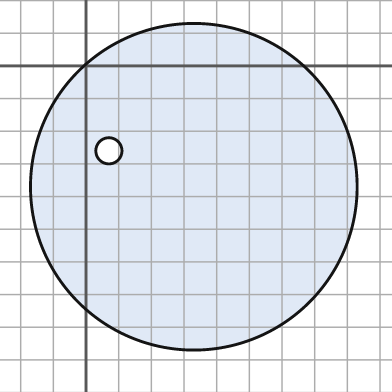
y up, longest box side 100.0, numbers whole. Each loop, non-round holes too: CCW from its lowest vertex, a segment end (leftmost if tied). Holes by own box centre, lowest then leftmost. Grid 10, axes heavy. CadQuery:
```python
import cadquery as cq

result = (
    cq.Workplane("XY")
    .moveTo(33.0, -37.0)
    .circle(50.0)
    .moveTo(7.0, -26.0)
    .circle(4.0)
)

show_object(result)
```